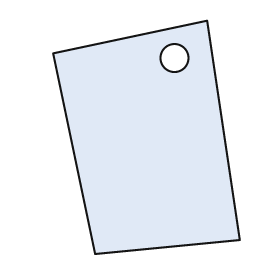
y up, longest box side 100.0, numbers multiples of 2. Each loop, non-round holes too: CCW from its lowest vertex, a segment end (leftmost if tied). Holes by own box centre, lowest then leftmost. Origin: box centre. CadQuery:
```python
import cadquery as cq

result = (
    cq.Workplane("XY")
    .moveTo(-22.0, -50.0)
    .lineTo(40.0, -44.0)
    .lineTo(26.0, 50.0)
    .lineTo(-40.0, 36.0)
    .close()
    .moveTo(12.0, 34.0)
    .circle(6.0)
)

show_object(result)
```